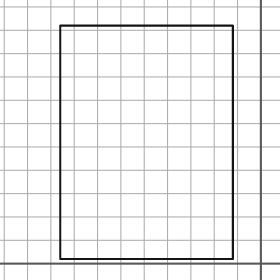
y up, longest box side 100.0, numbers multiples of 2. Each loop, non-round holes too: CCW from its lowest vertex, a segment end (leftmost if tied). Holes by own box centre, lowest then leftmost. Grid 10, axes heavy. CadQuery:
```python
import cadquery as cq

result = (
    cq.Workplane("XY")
    .moveTo(-86.0, 2.0)
    .lineTo(-12.0, 2.0)
    .lineTo(-12.0, 102.0)
    .lineTo(-86.0, 102.0)
    .close()
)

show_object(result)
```